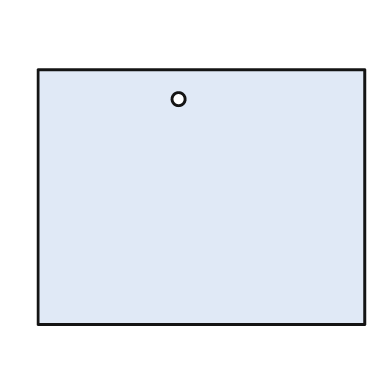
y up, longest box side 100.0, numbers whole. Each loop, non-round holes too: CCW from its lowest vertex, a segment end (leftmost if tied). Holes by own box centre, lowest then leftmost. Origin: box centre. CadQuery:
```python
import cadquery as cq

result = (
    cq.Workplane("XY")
    .moveTo(-50.0, -39.0)
    .lineTo(50.0, -39.0)
    .lineTo(50.0, 39.0)
    .lineTo(-50.0, 39.0)
    .close()
    .moveTo(-7.0, 30.0)
    .circle(2.0)
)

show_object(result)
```